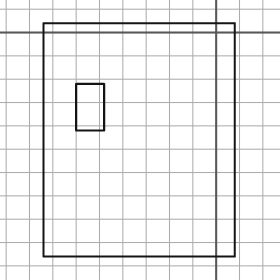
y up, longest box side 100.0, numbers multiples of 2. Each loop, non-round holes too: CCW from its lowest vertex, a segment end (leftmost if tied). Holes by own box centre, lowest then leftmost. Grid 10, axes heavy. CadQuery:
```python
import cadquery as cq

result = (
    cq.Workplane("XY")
    .moveTo(-74.0, -96.0)
    .lineTo(8.0, -96.0)
    .lineTo(8.0, 4.0)
    .lineTo(-74.0, 4.0)
    .close()
    .moveTo(-60.0, -42.0)
    .lineTo(-48.0, -42.0)
    .lineTo(-48.0, -22.0)
    .lineTo(-60.0, -22.0)
    .close()
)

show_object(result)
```